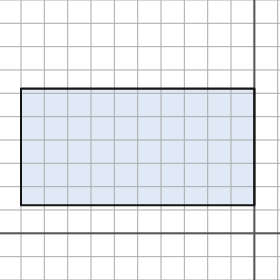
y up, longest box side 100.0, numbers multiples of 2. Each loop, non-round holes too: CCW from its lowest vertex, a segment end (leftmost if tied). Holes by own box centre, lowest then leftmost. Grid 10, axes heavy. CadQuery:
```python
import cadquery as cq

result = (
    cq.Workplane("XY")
    .moveTo(-100.0, 12.0)
    .lineTo(0.0, 12.0)
    .lineTo(0.0, 62.0)
    .lineTo(-100.0, 62.0)
    .close()
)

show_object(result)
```